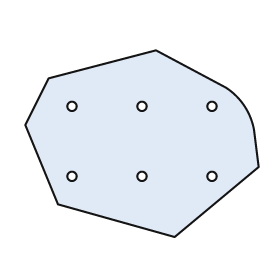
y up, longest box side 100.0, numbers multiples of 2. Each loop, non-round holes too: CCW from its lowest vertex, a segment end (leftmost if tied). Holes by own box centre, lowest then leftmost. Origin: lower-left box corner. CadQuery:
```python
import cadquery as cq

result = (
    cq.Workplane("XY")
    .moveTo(64.0, 0.0)
    .lineTo(100.0, 30.0)
    .lineTo(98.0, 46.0)
    .threePointArc((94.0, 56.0), (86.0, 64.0))
    .lineTo(56.0, 80.0)
    .lineTo(10.0, 68.0)
    .lineTo(0.0, 48.0)
    .lineTo(14.0, 14.0)
    .close()
    .moveTo(20.0, 26.0)
    .circle(2.0)
    .moveTo(50.0, 26.0)
    .circle(2.0)
    .moveTo(80.0, 26.0)
    .circle(2.0)
    .moveTo(20.0, 56.0)
    .circle(2.0)
    .moveTo(50.0, 56.0)
    .circle(2.0)
    .moveTo(80.0, 56.0)
    .circle(2.0)
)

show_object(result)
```